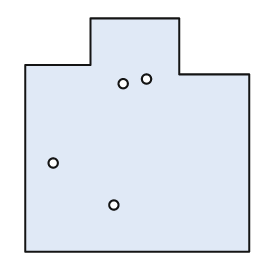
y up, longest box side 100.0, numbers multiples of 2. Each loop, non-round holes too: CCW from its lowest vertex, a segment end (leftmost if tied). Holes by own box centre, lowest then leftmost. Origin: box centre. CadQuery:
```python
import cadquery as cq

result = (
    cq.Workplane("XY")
    .moveTo(-48.0, -50.0)
    .lineTo(48.0, -50.0)
    .lineTo(48.0, 26.0)
    .lineTo(18.0, 26.0)
    .lineTo(18.0, 50.0)
    .lineTo(-20.0, 50.0)
    .lineTo(-20.0, 30.0)
    .lineTo(-48.0, 30.0)
    .close()
    .moveTo(-10.0, -30.0)
    .circle(2.0)
    .moveTo(-36.0, -12.0)
    .circle(2.0)
    .moveTo(-6.0, 22.0)
    .circle(2.0)
    .moveTo(4.0, 24.0)
    .circle(2.0)
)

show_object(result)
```